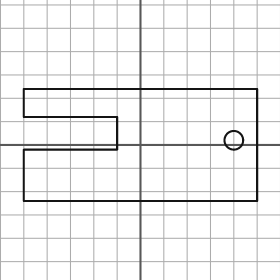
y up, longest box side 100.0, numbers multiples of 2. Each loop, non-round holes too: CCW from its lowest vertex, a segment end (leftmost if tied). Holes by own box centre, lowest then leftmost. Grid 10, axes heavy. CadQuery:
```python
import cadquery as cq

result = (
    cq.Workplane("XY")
    .moveTo(-50.0, -24.0)
    .lineTo(50.0, -24.0)
    .lineTo(50.0, 24.0)
    .lineTo(-50.0, 24.0)
    .lineTo(-50.0, 12.0)
    .lineTo(-10.0, 12.0)
    .lineTo(-10.0, -2.0)
    .lineTo(-50.0, -2.0)
    .close()
    .moveTo(40.0, 2.0)
    .circle(4.0)
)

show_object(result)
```